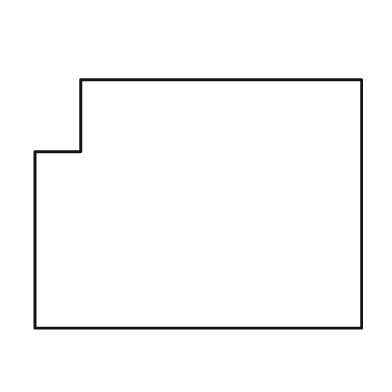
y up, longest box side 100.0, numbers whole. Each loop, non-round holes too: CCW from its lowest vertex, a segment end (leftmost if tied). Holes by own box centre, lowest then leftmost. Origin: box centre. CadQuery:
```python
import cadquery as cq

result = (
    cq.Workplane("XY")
    .moveTo(-50.0, -38.0)
    .lineTo(50.0, -38.0)
    .lineTo(50.0, 38.0)
    .lineTo(-36.0, 38.0)
    .lineTo(-36.0, 16.0)
    .lineTo(-50.0, 16.0)
    .close()
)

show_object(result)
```